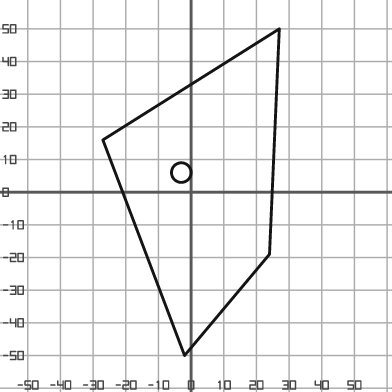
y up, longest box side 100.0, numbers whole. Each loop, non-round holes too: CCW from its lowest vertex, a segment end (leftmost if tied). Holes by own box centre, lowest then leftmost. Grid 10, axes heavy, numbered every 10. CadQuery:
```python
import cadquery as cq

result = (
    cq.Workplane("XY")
    .moveTo(-2.0, -50.0)
    .lineTo(24.0, -19.0)
    .lineTo(27.0, 50.0)
    .lineTo(-27.0, 16.0)
    .close()
    .moveTo(-3.0, 6.0)
    .circle(3.0)
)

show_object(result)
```